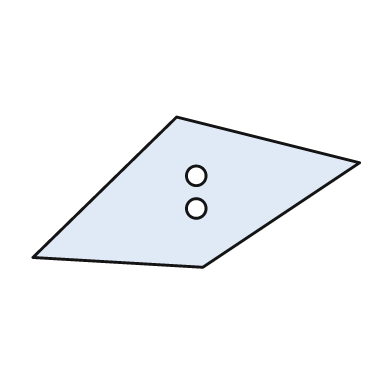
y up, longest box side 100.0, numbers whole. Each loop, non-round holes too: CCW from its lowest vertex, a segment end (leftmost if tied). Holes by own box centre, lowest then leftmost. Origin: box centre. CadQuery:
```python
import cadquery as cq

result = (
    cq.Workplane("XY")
    .moveTo(2.0, -23.0)
    .lineTo(50.0, 9.0)
    .lineTo(-6.0, 23.0)
    .lineTo(-50.0, -20.0)
    .close()
    .moveTo(0.0, -5.0)
    .circle(3.0)
    .moveTo(0.0, 5.0)
    .circle(3.0)
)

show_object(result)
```